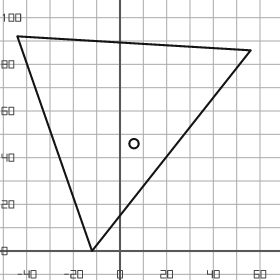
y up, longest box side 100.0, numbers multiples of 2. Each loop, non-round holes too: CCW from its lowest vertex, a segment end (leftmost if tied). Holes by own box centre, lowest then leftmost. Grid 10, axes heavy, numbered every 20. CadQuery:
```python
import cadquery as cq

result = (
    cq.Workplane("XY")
    .moveTo(-12.0, 0.0)
    .lineTo(56.0, 86.0)
    .lineTo(-44.0, 92.0)
    .close()
    .moveTo(6.0, 46.0)
    .circle(2.0)
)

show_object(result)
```